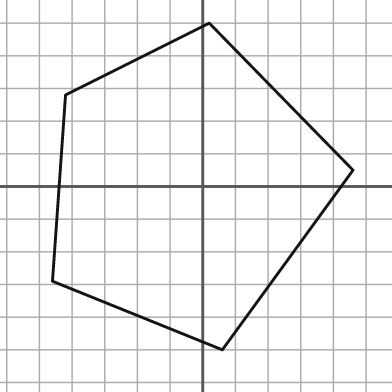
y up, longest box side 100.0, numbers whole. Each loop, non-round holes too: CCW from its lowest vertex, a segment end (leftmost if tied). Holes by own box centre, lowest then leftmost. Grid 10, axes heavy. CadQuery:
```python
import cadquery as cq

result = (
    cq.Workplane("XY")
    .moveTo(6.0, -50.0)
    .lineTo(46.0, 5.0)
    .lineTo(2.0, 50.0)
    .lineTo(-42.0, 28.0)
    .lineTo(-46.0, -29.0)
    .close()
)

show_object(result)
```